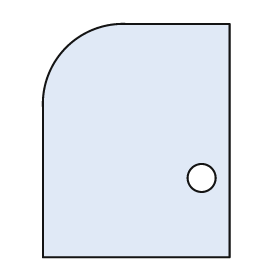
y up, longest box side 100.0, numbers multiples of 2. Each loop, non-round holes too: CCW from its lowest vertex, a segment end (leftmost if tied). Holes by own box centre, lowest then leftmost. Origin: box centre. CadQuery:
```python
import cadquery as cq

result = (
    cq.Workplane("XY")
    .moveTo(-40.0, -50.0)
    .lineTo(40.0, -50.0)
    .lineTo(40.0, 50.0)
    .lineTo(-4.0, 50.0)
    .threePointArc((-30.0, 40.0), (-40.0, 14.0))
    .close()
    .moveTo(28.0, -16.0)
    .circle(6.0)
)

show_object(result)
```